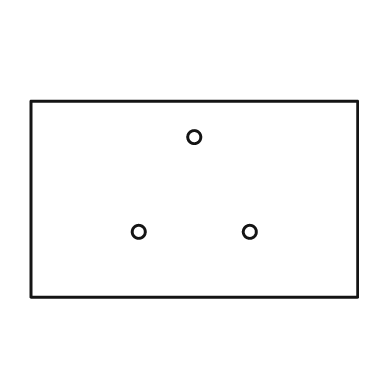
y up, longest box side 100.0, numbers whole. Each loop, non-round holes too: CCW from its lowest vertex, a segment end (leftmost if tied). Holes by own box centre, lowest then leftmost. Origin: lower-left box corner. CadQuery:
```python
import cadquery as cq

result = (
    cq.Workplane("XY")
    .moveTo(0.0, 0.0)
    .lineTo(100.0, 0.0)
    .lineTo(100.0, 60.0)
    .lineTo(0.0, 60.0)
    .close()
    .moveTo(33.0, 20.0)
    .circle(2.0)
    .moveTo(67.0, 20.0)
    .circle(2.0)
    .moveTo(50.0, 49.0)
    .circle(2.0)
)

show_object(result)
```